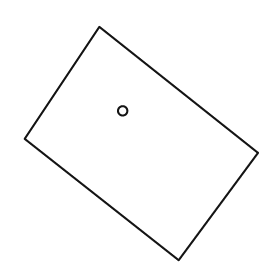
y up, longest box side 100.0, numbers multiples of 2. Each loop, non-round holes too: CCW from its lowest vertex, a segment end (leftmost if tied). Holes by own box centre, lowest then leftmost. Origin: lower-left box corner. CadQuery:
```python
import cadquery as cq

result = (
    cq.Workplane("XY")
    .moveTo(66.0, 0.0)
    .lineTo(100.0, 46.0)
    .lineTo(32.0, 100.0)
    .lineTo(0.0, 52.0)
    .close()
    .moveTo(42.0, 64.0)
    .circle(2.0)
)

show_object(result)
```